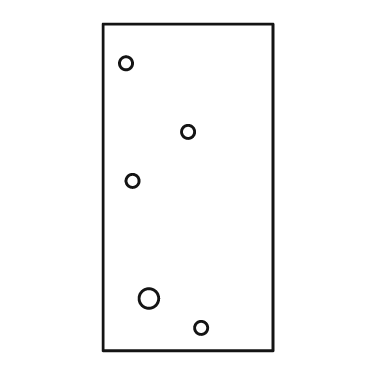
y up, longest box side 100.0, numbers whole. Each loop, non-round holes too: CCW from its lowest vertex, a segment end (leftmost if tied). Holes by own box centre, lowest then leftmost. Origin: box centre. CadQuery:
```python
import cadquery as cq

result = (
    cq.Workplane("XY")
    .moveTo(-26.0, -50.0)
    .lineTo(26.0, -50.0)
    .lineTo(26.0, 50.0)
    .lineTo(-26.0, 50.0)
    .close()
    .moveTo(4.0, -43.0)
    .circle(2.0)
    .moveTo(-12.0, -34.0)
    .circle(3.0)
    .moveTo(-17.0, 2.0)
    .circle(2.0)
    .moveTo(0.0, 17.0)
    .circle(2.0)
    .moveTo(-19.0, 38.0)
    .circle(2.0)
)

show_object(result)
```